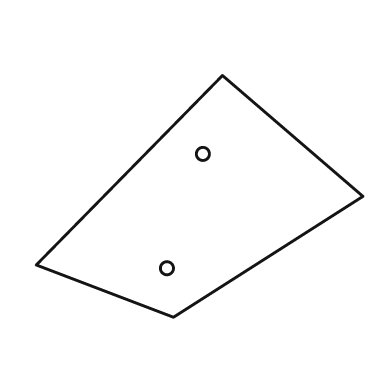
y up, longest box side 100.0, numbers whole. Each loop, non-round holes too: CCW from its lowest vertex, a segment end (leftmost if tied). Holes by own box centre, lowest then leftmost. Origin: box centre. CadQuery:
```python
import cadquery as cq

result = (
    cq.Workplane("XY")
    .moveTo(-8.0, -37.0)
    .lineTo(50.0, 0.0)
    .lineTo(7.0, 37.0)
    .lineTo(-50.0, -21.0)
    .close()
    .moveTo(-10.0, -22.0)
    .circle(2.0)
    .moveTo(1.0, 13.0)
    .circle(2.0)
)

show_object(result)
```